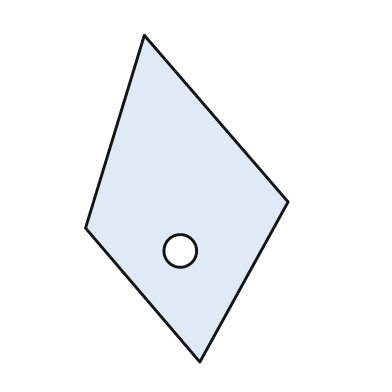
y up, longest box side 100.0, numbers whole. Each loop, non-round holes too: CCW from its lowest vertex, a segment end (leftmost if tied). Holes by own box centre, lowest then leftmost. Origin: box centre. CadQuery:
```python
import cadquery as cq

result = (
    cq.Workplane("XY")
    .moveTo(4.0, -50.0)
    .lineTo(31.0, -1.0)
    .lineTo(-13.0, 50.0)
    .lineTo(-31.0, -9.0)
    .close()
    .moveTo(-2.0, -16.0)
    .circle(5.0)
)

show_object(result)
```